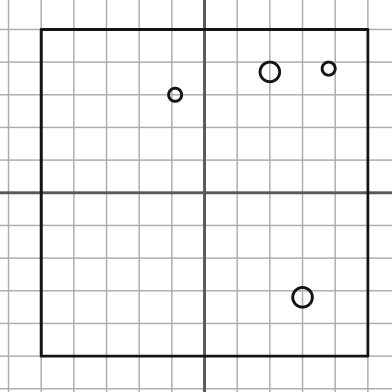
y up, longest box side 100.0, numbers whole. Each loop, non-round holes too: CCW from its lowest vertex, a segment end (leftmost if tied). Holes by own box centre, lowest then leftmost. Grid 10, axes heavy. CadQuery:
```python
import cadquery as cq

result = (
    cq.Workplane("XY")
    .moveTo(-50.0, -50.0)
    .lineTo(50.0, -50.0)
    .lineTo(50.0, 50.0)
    .lineTo(-50.0, 50.0)
    .close()
    .moveTo(30.0, -32.0)
    .circle(3.0)
    .moveTo(-9.0, 30.0)
    .circle(2.0)
    .moveTo(20.0, 37.0)
    .circle(3.0)
    .moveTo(38.0, 38.0)
    .circle(2.0)
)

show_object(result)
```